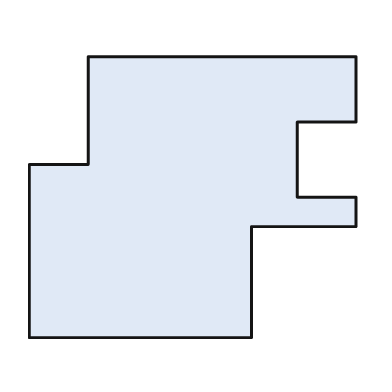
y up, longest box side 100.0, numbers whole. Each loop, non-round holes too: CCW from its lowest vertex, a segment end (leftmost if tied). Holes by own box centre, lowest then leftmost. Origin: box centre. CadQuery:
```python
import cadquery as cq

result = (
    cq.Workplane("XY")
    .moveTo(-50.0, -43.0)
    .lineTo(18.0, -43.0)
    .lineTo(18.0, -9.0)
    .lineTo(50.0, -9.0)
    .lineTo(50.0, 0.0)
    .lineTo(32.0, 0.0)
    .lineTo(32.0, 23.0)
    .lineTo(50.0, 23.0)
    .lineTo(50.0, 43.0)
    .lineTo(-32.0, 43.0)
    .lineTo(-32.0, 10.0)
    .lineTo(-50.0, 10.0)
    .close()
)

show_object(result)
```